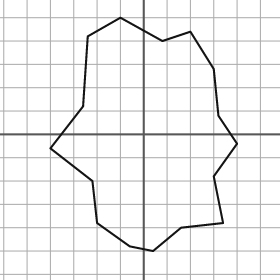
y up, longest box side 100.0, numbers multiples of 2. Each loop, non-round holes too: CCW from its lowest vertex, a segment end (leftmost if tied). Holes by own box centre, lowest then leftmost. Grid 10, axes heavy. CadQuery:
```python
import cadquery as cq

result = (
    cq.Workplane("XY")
    .moveTo(4.0, -50.0)
    .lineTo(16.0, -40.0)
    .lineTo(34.0, -38.0)
    .lineTo(30.0, -18.0)
    .lineTo(40.0, -4.0)
    .lineTo(32.0, 8.0)
    .lineTo(30.0, 28.0)
    .lineTo(20.0, 44.0)
    .lineTo(8.0, 40.0)
    .lineTo(-10.0, 50.0)
    .lineTo(-24.0, 42.0)
    .lineTo(-26.0, 12.0)
    .lineTo(-40.0, -6.0)
    .lineTo(-22.0, -20.0)
    .lineTo(-20.0, -38.0)
    .lineTo(-6.0, -48.0)
    .close()
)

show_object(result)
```